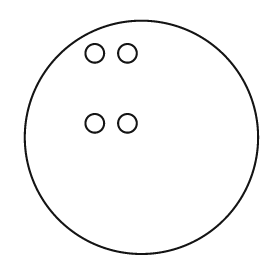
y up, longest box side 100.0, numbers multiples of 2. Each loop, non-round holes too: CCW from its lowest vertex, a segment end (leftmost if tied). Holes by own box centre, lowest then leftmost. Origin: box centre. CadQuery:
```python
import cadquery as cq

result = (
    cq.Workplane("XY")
    .moveTo(0.0, 0.0)
    .circle(50.0)
    .moveTo(-20.0, 6.0)
    .circle(4.0)
    .moveTo(-6.0, 6.0)
    .circle(4.0)
    .moveTo(-20.0, 36.0)
    .circle(4.0)
    .moveTo(-6.0, 36.0)
    .circle(4.0)
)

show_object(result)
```